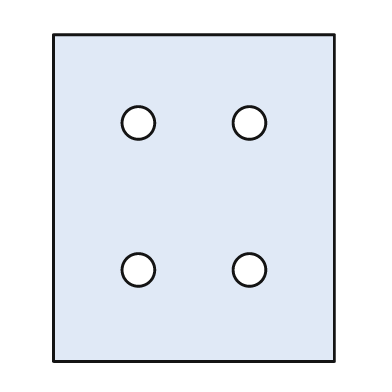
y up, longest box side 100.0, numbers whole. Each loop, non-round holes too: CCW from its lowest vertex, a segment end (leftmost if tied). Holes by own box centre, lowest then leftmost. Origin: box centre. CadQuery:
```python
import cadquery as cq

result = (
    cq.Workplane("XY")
    .moveTo(-43.0, -50.0)
    .lineTo(43.0, -50.0)
    .lineTo(43.0, 50.0)
    .lineTo(-43.0, 50.0)
    .close()
    .moveTo(-17.0, -22.0)
    .circle(5.0)
    .moveTo(17.0, -22.0)
    .circle(5.0)
    .moveTo(-17.0, 23.0)
    .circle(5.0)
    .moveTo(17.0, 23.0)
    .circle(5.0)
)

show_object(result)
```